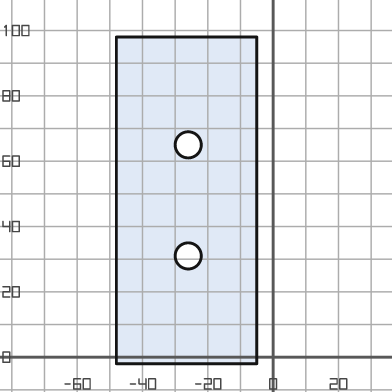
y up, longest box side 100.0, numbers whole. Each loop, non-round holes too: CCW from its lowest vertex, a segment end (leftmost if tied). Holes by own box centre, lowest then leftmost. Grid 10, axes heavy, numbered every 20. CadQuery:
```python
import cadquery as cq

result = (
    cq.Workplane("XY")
    .moveTo(-48.0, -2.0)
    .lineTo(-5.0, -2.0)
    .lineTo(-5.0, 98.0)
    .lineTo(-48.0, 98.0)
    .close()
    .moveTo(-26.0, 31.0)
    .circle(4.0)
    .moveTo(-26.0, 65.0)
    .circle(4.0)
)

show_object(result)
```